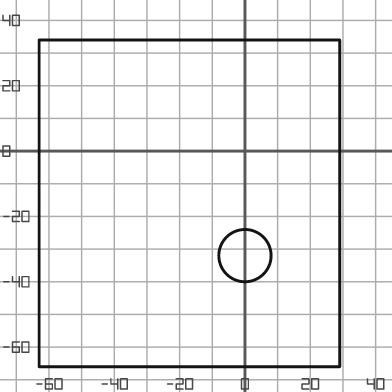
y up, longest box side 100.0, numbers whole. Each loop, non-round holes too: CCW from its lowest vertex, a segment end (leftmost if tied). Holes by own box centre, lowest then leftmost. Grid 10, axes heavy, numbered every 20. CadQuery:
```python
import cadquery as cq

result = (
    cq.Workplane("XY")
    .moveTo(-63.0, -66.0)
    .lineTo(29.0, -66.0)
    .lineTo(29.0, 34.0)
    .lineTo(-63.0, 34.0)
    .close()
    .moveTo(0.0, -32.0)
    .circle(8.0)
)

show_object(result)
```